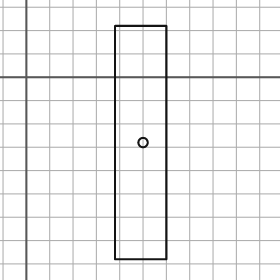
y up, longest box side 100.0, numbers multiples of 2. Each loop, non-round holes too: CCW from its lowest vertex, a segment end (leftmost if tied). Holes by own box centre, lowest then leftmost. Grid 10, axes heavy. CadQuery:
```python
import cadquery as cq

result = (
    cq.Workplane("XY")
    .moveTo(38.0, -78.0)
    .lineTo(60.0, -78.0)
    .lineTo(60.0, 22.0)
    .lineTo(38.0, 22.0)
    .close()
    .moveTo(50.0, -28.0)
    .circle(2.0)
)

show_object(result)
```